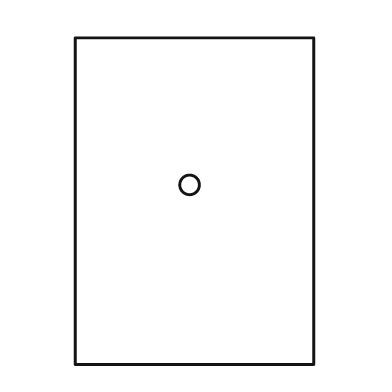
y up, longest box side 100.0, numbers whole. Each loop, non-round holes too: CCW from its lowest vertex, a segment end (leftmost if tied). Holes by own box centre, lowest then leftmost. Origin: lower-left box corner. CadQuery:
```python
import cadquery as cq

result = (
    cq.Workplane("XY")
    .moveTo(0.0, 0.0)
    .lineTo(73.0, 0.0)
    .lineTo(73.0, 100.0)
    .lineTo(0.0, 100.0)
    .close()
    .moveTo(35.0, 55.0)
    .circle(3.0)
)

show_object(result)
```